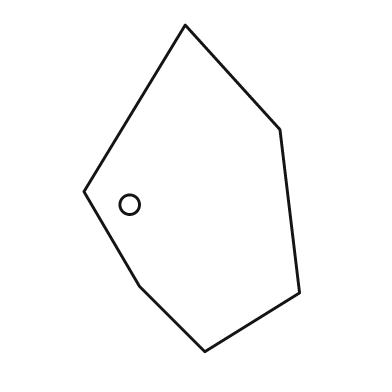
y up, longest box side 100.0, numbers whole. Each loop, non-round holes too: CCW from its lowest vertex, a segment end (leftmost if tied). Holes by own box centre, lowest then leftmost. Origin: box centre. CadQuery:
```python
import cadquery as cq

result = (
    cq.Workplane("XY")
    .moveTo(4.0, -50.0)
    .lineTo(33.0, -32.0)
    .lineTo(27.0, 18.0)
    .lineTo(-2.0, 50.0)
    .lineTo(-33.0, -1.0)
    .lineTo(-16.0, -30.0)
    .close()
    .moveTo(-19.0, -5.0)
    .circle(3.0)
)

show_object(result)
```